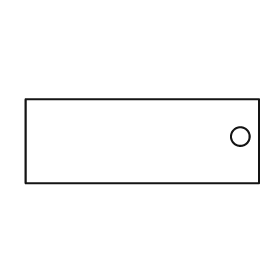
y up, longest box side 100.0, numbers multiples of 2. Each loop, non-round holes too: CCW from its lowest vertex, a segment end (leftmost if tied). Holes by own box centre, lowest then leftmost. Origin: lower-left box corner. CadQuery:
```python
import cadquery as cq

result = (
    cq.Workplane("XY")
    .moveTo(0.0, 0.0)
    .lineTo(100.0, 0.0)
    .lineTo(100.0, 36.0)
    .lineTo(0.0, 36.0)
    .close()
    .moveTo(92.0, 20.0)
    .circle(4.0)
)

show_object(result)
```